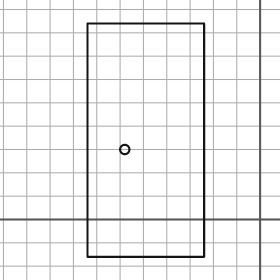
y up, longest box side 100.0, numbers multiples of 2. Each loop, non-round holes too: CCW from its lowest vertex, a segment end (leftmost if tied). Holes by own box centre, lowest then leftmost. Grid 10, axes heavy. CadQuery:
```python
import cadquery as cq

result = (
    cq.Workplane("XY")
    .moveTo(-74.0, -16.0)
    .lineTo(-24.0, -16.0)
    .lineTo(-24.0, 84.0)
    .lineTo(-74.0, 84.0)
    .close()
    .moveTo(-58.0, 30.0)
    .circle(2.0)
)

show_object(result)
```